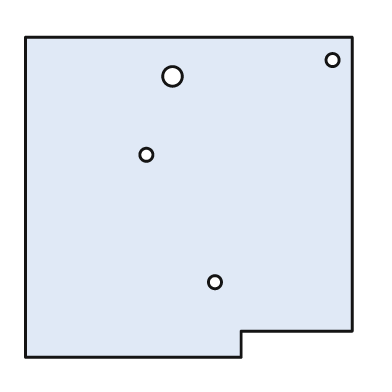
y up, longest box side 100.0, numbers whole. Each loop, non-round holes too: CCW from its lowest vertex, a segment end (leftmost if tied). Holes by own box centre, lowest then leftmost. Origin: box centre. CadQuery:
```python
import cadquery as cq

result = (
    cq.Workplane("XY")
    .moveTo(-50.0, -49.0)
    .lineTo(16.0, -49.0)
    .lineTo(16.0, -41.0)
    .lineTo(50.0, -41.0)
    .lineTo(50.0, 49.0)
    .lineTo(-50.0, 49.0)
    .close()
    .moveTo(8.0, -26.0)
    .circle(2.0)
    .moveTo(-13.0, 13.0)
    .circle(2.0)
    .moveTo(-5.0, 37.0)
    .circle(3.0)
    .moveTo(44.0, 42.0)
    .circle(2.0)
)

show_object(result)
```